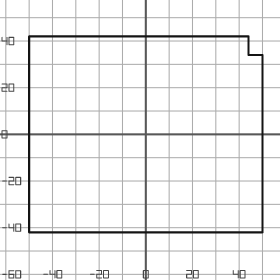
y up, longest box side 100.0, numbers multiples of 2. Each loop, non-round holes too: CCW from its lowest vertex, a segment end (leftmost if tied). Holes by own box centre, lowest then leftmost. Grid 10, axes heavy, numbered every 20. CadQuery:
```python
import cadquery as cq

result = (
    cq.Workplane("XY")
    .moveTo(-50.0, -42.0)
    .lineTo(50.0, -42.0)
    .lineTo(50.0, 34.0)
    .lineTo(44.0, 34.0)
    .lineTo(44.0, 42.0)
    .lineTo(-50.0, 42.0)
    .close()
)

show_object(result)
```